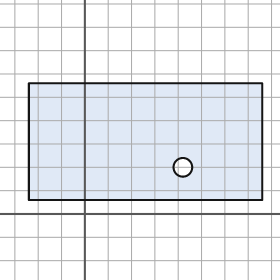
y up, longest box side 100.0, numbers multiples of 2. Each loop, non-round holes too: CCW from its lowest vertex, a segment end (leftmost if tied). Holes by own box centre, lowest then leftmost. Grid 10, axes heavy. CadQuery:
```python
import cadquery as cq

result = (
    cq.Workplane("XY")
    .moveTo(-24.0, 6.0)
    .lineTo(76.0, 6.0)
    .lineTo(76.0, 56.0)
    .lineTo(-24.0, 56.0)
    .close()
    .moveTo(42.0, 20.0)
    .circle(4.0)
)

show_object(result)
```